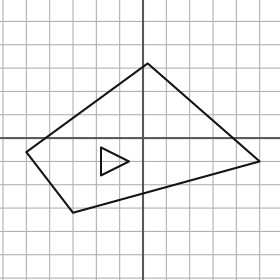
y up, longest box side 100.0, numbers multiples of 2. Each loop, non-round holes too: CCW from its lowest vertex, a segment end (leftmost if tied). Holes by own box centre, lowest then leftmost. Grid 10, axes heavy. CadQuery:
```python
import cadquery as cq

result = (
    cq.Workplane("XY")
    .moveTo(-30.0, -32.0)
    .lineTo(50.0, -10.0)
    .lineTo(2.0, 32.0)
    .lineTo(-50.0, -6.0)
    .close()
    .moveTo(-18.0, -16.0)
    .lineTo(-6.0, -10.0)
    .lineTo(-18.0, -4.0)
    .close()
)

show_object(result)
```